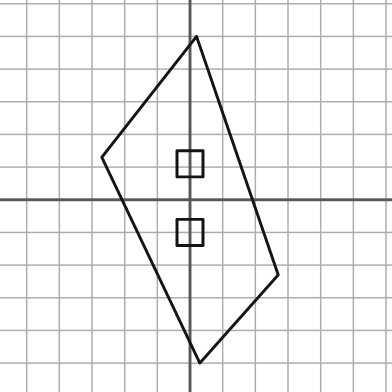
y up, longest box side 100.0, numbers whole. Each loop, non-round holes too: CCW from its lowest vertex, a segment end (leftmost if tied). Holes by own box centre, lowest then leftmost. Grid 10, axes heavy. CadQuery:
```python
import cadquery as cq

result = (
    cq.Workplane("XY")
    .moveTo(3.0, -50.0)
    .lineTo(27.0, -23.0)
    .lineTo(2.0, 50.0)
    .lineTo(-27.0, 13.0)
    .close()
    .moveTo(-4.0, -14.0)
    .lineTo(4.0, -14.0)
    .lineTo(4.0, -6.0)
    .lineTo(-4.0, -6.0)
    .close()
    .moveTo(-4.0, 7.0)
    .lineTo(4.0, 7.0)
    .lineTo(4.0, 15.0)
    .lineTo(-4.0, 15.0)
    .close()
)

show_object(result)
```